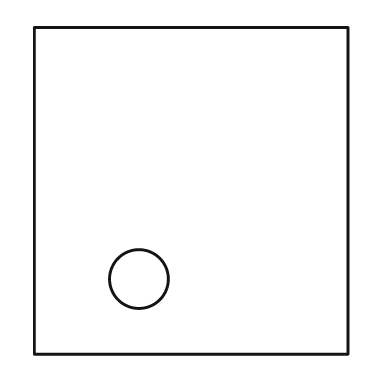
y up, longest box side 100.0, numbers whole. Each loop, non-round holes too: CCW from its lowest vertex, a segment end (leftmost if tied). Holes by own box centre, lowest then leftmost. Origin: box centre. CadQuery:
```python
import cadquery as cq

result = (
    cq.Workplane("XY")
    .moveTo(-48.0, -50.0)
    .lineTo(48.0, -50.0)
    .lineTo(48.0, 50.0)
    .lineTo(-48.0, 50.0)
    .close()
    .moveTo(-16.0, -27.0)
    .circle(9.0)
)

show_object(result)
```